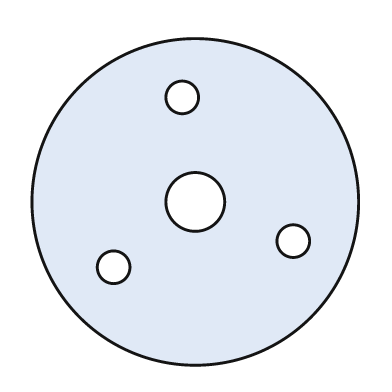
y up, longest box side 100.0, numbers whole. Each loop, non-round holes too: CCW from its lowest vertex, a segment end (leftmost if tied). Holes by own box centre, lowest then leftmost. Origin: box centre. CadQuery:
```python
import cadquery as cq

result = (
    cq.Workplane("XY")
    .moveTo(0.0, 0.0)
    .circle(50.0)
    .moveTo(-25.0, -20.0)
    .circle(5.0)
    .moveTo(30.0, -12.0)
    .circle(5.0)
    .moveTo(0.0, 0.0)
    .circle(9.0)
    .moveTo(-4.0, 32.0)
    .circle(5.0)
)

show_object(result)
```